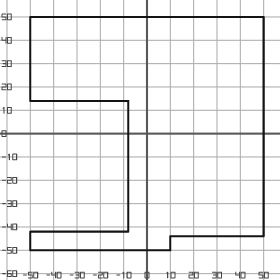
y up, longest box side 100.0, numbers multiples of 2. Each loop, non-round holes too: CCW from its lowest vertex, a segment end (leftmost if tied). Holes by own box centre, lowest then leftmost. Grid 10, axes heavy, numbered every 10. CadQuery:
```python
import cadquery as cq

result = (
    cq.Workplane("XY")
    .moveTo(-50.0, -50.0)
    .lineTo(10.0, -50.0)
    .lineTo(10.0, -44.0)
    .lineTo(50.0, -44.0)
    .lineTo(50.0, 50.0)
    .lineTo(-50.0, 50.0)
    .lineTo(-50.0, 14.0)
    .lineTo(-8.0, 14.0)
    .lineTo(-8.0, -42.0)
    .lineTo(-50.0, -42.0)
    .close()
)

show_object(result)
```